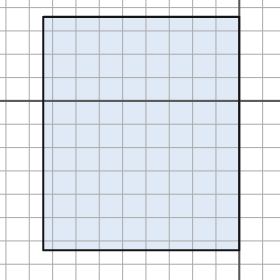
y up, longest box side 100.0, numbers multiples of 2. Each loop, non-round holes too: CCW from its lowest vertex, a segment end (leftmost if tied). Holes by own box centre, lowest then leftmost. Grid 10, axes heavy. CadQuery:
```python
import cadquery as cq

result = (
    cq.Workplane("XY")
    .moveTo(-84.0, -64.0)
    .lineTo(0.0, -64.0)
    .lineTo(0.0, 36.0)
    .lineTo(-84.0, 36.0)
    .close()
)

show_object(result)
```